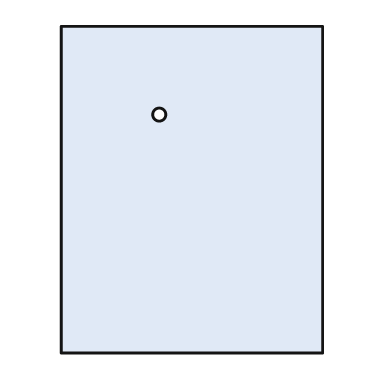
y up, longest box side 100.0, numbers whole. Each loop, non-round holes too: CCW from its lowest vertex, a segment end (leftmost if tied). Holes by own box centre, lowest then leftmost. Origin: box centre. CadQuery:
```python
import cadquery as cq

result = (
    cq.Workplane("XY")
    .moveTo(-40.0, -50.0)
    .lineTo(40.0, -50.0)
    .lineTo(40.0, 50.0)
    .lineTo(-40.0, 50.0)
    .close()
    .moveTo(-10.0, 23.0)
    .circle(2.0)
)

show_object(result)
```